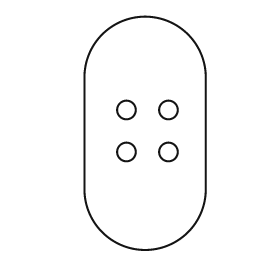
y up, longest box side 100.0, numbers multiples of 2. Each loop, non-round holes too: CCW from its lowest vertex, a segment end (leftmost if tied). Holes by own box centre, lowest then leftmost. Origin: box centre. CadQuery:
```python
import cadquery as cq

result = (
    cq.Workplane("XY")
    .moveTo(-26.0, -24.0)
    .threePointArc((0.0, -50.0), (26.0, -24.0))
    .lineTo(26.0, 24.0)
    .threePointArc((0.0, 50.0), (-26.0, 24.0))
    .close()
    .moveTo(-8.0, -8.0)
    .circle(4.0)
    .moveTo(10.0, -8.0)
    .circle(4.0)
    .moveTo(-8.0, 10.0)
    .circle(4.0)
    .moveTo(10.0, 10.0)
    .circle(4.0)
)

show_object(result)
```